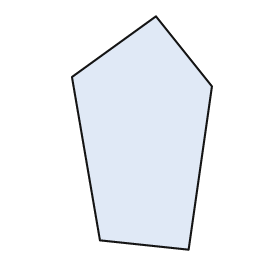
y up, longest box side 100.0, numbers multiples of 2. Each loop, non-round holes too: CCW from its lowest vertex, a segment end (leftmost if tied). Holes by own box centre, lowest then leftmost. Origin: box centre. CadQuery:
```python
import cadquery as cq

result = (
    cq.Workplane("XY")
    .moveTo(20.0, -50.0)
    .lineTo(30.0, 20.0)
    .lineTo(6.0, 50.0)
    .lineTo(-30.0, 24.0)
    .lineTo(-18.0, -46.0)
    .close()
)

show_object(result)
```